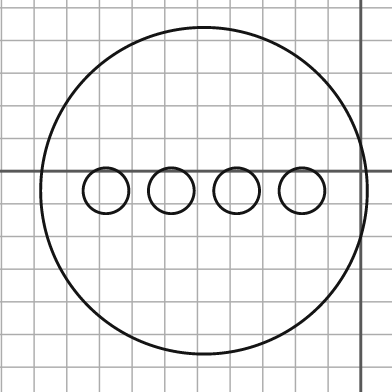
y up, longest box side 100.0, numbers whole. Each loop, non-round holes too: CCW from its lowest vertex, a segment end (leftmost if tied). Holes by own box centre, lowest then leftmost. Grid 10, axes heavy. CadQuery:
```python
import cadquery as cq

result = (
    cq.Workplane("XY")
    .moveTo(-48.0, -6.0)
    .circle(50.0)
    .moveTo(-78.0, -6.0)
    .circle(7.0)
    .moveTo(-58.0, -6.0)
    .circle(7.0)
    .moveTo(-38.0, -6.0)
    .circle(7.0)
    .moveTo(-18.0, -6.0)
    .circle(7.0)
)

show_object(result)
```